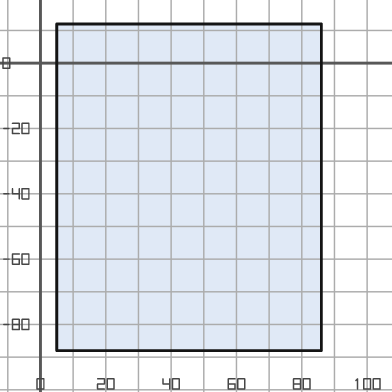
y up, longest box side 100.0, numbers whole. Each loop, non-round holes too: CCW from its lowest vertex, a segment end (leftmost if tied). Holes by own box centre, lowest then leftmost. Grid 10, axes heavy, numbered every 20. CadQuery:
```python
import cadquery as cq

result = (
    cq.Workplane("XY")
    .moveTo(5.0, -88.0)
    .lineTo(86.0, -88.0)
    .lineTo(86.0, 12.0)
    .lineTo(5.0, 12.0)
    .close()
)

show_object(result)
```